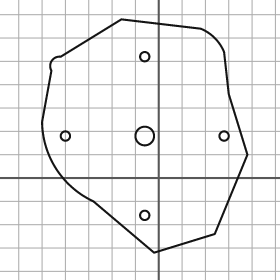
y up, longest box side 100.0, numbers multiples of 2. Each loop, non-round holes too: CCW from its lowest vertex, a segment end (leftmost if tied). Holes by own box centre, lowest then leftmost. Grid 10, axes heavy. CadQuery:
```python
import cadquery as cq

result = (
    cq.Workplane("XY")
    .moveTo(-2.0, -32.0)
    .lineTo(24.0, -24.0)
    .lineTo(38.0, 10.0)
    .lineTo(30.0, 36.0)
    .lineTo(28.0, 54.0)
    .threePointArc((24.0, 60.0), (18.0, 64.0))
    .lineTo(-16.0, 68.0)
    .lineTo(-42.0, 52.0)
    .threePointArc((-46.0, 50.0), (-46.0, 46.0))
    .lineTo(-50.0, 24.0)
    .threePointArc((-44.0, 4.0), (-28.0, -10.0))
    .close()
    .moveTo(-6.0, -16.0)
    .circle(2.0)
    .moveTo(-40.0, 18.0)
    .circle(2.0)
    .moveTo(-6.0, 18.0)
    .circle(4.0)
    .moveTo(28.0, 18.0)
    .circle(2.0)
    .moveTo(-6.0, 52.0)
    .circle(2.0)
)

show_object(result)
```